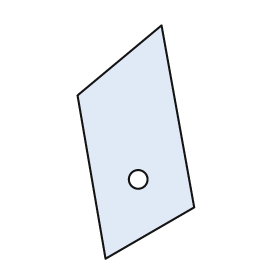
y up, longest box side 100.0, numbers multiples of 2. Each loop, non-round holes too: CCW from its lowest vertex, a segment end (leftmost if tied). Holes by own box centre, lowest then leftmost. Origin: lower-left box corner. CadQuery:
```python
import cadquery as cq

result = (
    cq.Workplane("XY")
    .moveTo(12.0, 0.0)
    .lineTo(50.0, 22.0)
    .lineTo(36.0, 100.0)
    .lineTo(0.0, 70.0)
    .close()
    .moveTo(26.0, 34.0)
    .circle(4.0)
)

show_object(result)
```